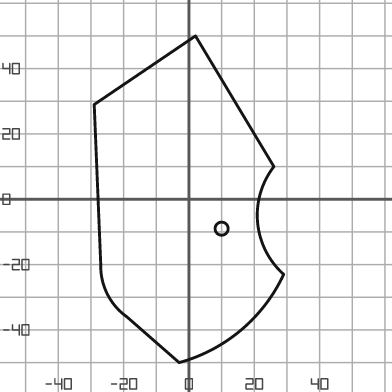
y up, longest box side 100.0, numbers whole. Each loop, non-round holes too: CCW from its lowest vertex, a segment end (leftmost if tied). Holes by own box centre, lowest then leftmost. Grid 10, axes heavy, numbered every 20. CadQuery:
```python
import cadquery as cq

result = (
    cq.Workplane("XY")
    .moveTo(-3.0, -50.0)
    .threePointArc((16.0, -40.0), (29.0, -23.0))
    .threePointArc((21.0, -7.0), (26.0, 10.0))
    .lineTo(2.0, 50.0)
    .lineTo(-29.0, 29.0)
    .lineTo(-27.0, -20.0)
    .threePointArc((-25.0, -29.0), (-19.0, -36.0))
    .close()
    .moveTo(10.0, -9.0)
    .circle(2.0)
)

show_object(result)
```